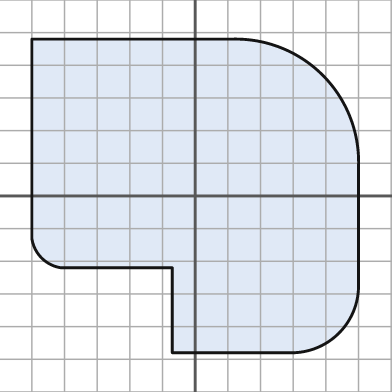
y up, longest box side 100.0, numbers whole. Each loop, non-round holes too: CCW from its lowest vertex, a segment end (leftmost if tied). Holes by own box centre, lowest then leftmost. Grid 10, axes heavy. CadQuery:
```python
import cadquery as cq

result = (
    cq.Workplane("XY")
    .moveTo(-7.0, -48.0)
    .lineTo(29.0, -48.0)
    .threePointArc((44.0, -42.0), (50.0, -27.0))
    .lineTo(50.0, 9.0)
    .threePointArc((39.0, 37.0), (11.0, 48.0))
    .lineTo(-50.0, 48.0)
    .lineTo(-50.0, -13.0)
    .threePointArc((-47.0, -19.0), (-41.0, -22.0))
    .lineTo(-7.0, -22.0)
    .close()
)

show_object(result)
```